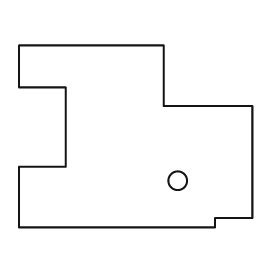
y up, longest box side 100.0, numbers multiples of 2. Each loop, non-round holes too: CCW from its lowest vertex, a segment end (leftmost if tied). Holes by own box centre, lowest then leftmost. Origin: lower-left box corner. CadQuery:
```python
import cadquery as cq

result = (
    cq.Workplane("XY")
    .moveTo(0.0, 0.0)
    .lineTo(84.0, 0.0)
    .lineTo(84.0, 4.0)
    .lineTo(100.0, 4.0)
    .lineTo(100.0, 52.0)
    .lineTo(62.0, 52.0)
    .lineTo(62.0, 78.0)
    .lineTo(0.0, 78.0)
    .lineTo(0.0, 60.0)
    .lineTo(20.0, 60.0)
    .lineTo(20.0, 26.0)
    .lineTo(0.0, 26.0)
    .close()
    .moveTo(68.0, 20.0)
    .circle(4.0)
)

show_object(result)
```